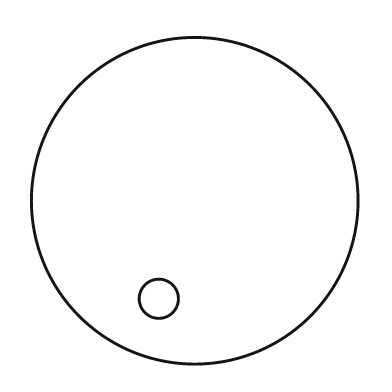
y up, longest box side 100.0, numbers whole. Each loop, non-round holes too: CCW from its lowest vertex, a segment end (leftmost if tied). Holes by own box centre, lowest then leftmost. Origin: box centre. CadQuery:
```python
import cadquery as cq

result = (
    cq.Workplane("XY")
    .moveTo(0.0, 0.0)
    .circle(50.0)
    .moveTo(-11.0, -30.0)
    .circle(6.0)
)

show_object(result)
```